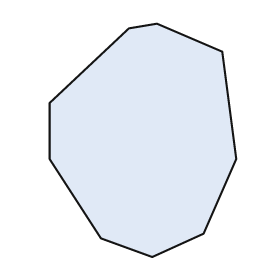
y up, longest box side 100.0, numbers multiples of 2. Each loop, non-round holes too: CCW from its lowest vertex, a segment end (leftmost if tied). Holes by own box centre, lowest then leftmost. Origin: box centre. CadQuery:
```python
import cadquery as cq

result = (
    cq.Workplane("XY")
    .moveTo(4.0, -50.0)
    .lineTo(26.0, -40.0)
    .lineTo(40.0, -8.0)
    .lineTo(34.0, 38.0)
    .lineTo(6.0, 50.0)
    .lineTo(-6.0, 48.0)
    .lineTo(-40.0, 16.0)
    .lineTo(-40.0, -8.0)
    .lineTo(-18.0, -42.0)
    .close()
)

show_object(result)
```